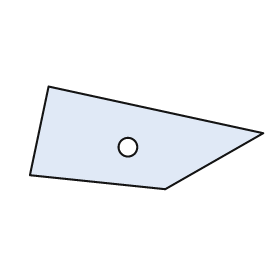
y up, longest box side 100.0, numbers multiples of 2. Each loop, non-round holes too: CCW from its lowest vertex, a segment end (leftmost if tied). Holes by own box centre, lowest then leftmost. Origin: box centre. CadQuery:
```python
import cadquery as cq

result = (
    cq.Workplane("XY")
    .moveTo(8.0, -22.0)
    .lineTo(50.0, 2.0)
    .lineTo(-42.0, 22.0)
    .lineTo(-50.0, -16.0)
    .close()
    .moveTo(-8.0, -4.0)
    .circle(4.0)
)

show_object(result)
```